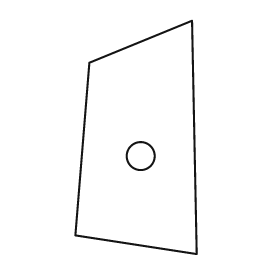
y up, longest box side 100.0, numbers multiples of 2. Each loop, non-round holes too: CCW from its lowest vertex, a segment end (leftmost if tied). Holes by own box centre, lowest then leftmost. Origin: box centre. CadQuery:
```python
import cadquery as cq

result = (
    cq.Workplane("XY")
    .moveTo(26.0, -50.0)
    .lineTo(24.0, 50.0)
    .lineTo(-20.0, 32.0)
    .lineTo(-26.0, -42.0)
    .close()
    .moveTo(2.0, -8.0)
    .circle(6.0)
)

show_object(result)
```